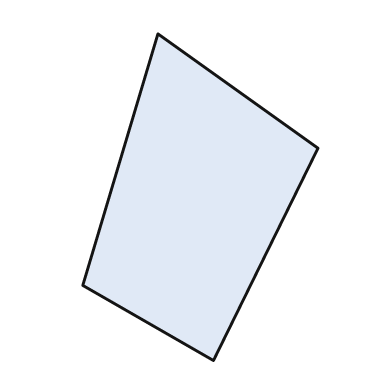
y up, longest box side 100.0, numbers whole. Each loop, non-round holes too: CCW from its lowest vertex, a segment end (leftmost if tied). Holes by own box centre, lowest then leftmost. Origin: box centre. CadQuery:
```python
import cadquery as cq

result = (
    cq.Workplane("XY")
    .moveTo(4.0, -50.0)
    .lineTo(36.0, 15.0)
    .lineTo(-13.0, 50.0)
    .lineTo(-36.0, -27.0)
    .close()
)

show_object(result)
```